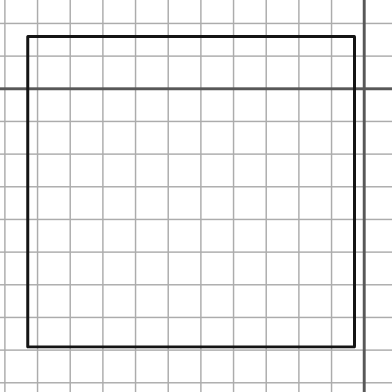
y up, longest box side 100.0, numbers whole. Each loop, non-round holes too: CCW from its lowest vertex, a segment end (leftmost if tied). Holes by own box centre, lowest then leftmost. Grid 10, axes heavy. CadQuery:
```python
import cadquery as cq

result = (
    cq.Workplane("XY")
    .moveTo(-103.0, -79.0)
    .lineTo(-3.0, -79.0)
    .lineTo(-3.0, 16.0)
    .lineTo(-103.0, 16.0)
    .close()
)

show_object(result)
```